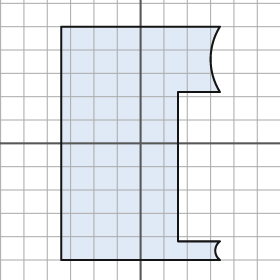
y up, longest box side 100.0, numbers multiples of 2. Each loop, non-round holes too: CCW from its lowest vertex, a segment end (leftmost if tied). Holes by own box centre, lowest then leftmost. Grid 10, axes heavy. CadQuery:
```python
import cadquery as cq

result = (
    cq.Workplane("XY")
    .moveTo(-34.0, -50.0)
    .lineTo(34.0, -50.0)
    .threePointArc((32.0, -46.0), (34.0, -42.0))
    .lineTo(16.0, -42.0)
    .lineTo(16.0, 22.0)
    .lineTo(34.0, 22.0)
    .threePointArc((30.0, 36.0), (34.0, 50.0))
    .lineTo(-34.0, 50.0)
    .close()
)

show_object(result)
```